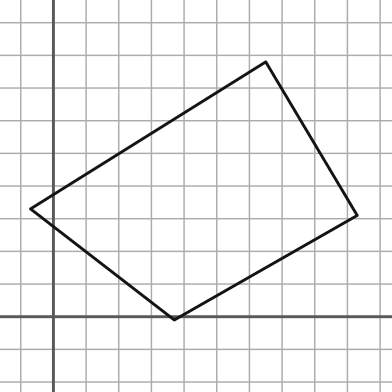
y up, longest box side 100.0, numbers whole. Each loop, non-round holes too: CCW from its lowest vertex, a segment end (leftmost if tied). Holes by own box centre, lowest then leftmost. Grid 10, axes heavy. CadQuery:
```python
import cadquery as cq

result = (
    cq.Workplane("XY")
    .moveTo(37.0, -1.0)
    .lineTo(93.0, 31.0)
    .lineTo(65.0, 78.0)
    .lineTo(-7.0, 33.0)
    .close()
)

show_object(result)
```